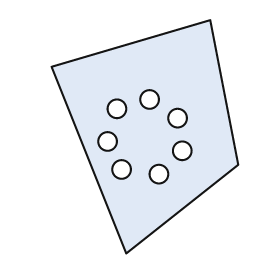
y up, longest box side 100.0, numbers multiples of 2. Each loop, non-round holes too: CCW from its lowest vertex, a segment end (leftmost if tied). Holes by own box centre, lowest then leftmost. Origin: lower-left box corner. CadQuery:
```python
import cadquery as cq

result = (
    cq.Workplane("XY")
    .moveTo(32.0, 0.0)
    .lineTo(80.0, 38.0)
    .lineTo(68.0, 100.0)
    .lineTo(0.0, 80.0)
    .close()
    .moveTo(46.0, 34.0)
    .circle(4.0)
    .moveTo(30.0, 36.0)
    .circle(4.0)
    .moveTo(56.0, 44.0)
    .circle(4.0)
    .moveTo(24.0, 48.0)
    .circle(4.0)
    .moveTo(54.0, 58.0)
    .circle(4.0)
    .moveTo(28.0, 62.0)
    .circle(4.0)
    .moveTo(42.0, 66.0)
    .circle(4.0)
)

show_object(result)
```